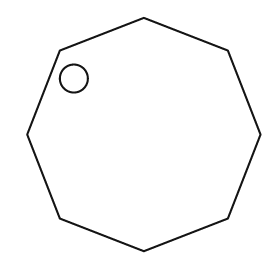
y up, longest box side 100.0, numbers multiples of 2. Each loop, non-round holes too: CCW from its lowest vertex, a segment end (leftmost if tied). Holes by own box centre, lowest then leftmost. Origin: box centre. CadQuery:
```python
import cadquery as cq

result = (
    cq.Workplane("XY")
    .moveTo(0.0, -50.0)
    .lineTo(36.0, -36.0)
    .lineTo(50.0, 0.0)
    .lineTo(36.0, 36.0)
    .lineTo(0.0, 50.0)
    .lineTo(-36.0, 36.0)
    .lineTo(-50.0, 0.0)
    .lineTo(-36.0, -36.0)
    .close()
    .moveTo(-30.0, 24.0)
    .circle(6.0)
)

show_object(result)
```